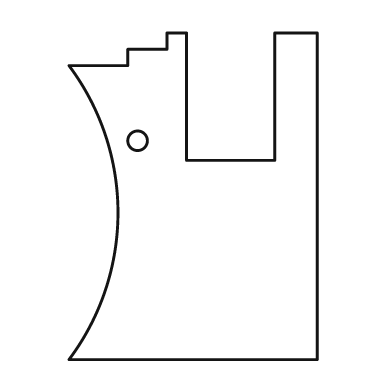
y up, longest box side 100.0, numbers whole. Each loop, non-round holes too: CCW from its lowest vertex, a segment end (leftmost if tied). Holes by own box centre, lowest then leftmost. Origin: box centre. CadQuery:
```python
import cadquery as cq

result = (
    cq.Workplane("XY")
    .moveTo(-38.0, -50.0)
    .lineTo(38.0, -50.0)
    .lineTo(38.0, 50.0)
    .lineTo(25.0, 50.0)
    .lineTo(25.0, 11.0)
    .lineTo(-2.0, 11.0)
    .lineTo(-2.0, 50.0)
    .lineTo(-8.0, 50.0)
    .lineTo(-8.0, 45.0)
    .lineTo(-20.0, 45.0)
    .lineTo(-20.0, 40.0)
    .lineTo(-38.0, 40.0)
    .threePointArc((-23.0, -5.0), (-38.0, -50.0))
    .close()
    .moveTo(-17.0, 17.0)
    .circle(3.0)
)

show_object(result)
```